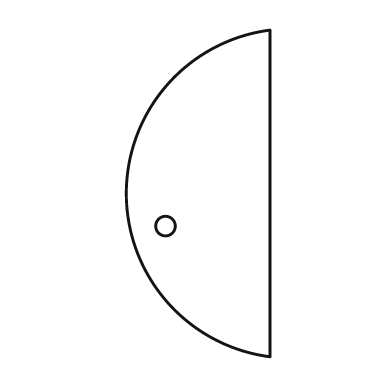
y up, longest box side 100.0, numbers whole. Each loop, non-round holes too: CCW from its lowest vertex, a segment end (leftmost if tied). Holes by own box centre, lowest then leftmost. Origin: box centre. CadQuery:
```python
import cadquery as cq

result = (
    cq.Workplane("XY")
    .moveTo(22.0, -50.0)
    .lineTo(22.0, 50.0)
    .threePointArc((-22.0, 0.0), (22.0, -50.0))
    .close()
    .moveTo(-10.0, -10.0)
    .circle(3.0)
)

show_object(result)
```